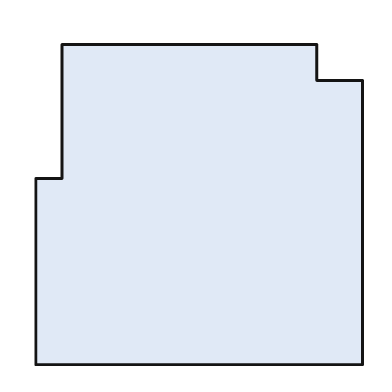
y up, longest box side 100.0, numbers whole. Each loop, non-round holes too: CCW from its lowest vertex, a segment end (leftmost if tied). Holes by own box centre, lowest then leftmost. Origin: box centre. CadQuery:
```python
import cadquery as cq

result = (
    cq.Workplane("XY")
    .moveTo(-50.0, -49.0)
    .lineTo(50.0, -49.0)
    .lineTo(50.0, 38.0)
    .lineTo(36.0, 38.0)
    .lineTo(36.0, 49.0)
    .lineTo(-42.0, 49.0)
    .lineTo(-42.0, 8.0)
    .lineTo(-50.0, 8.0)
    .close()
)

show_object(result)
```